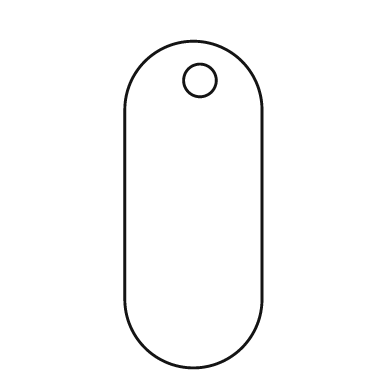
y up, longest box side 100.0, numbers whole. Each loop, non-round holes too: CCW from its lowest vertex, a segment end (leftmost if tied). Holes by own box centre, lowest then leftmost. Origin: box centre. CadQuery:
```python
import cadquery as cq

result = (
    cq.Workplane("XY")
    .moveTo(-21.0, -29.0)
    .threePointArc((0.0, -50.0), (21.0, -29.0))
    .lineTo(21.0, 29.0)
    .threePointArc((0.0, 50.0), (-21.0, 29.0))
    .close()
    .moveTo(2.0, 38.0)
    .circle(5.0)
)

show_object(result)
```